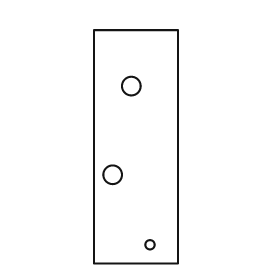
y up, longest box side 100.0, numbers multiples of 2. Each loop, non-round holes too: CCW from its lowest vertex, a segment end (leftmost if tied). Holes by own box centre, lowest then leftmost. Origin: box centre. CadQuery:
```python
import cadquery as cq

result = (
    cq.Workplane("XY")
    .moveTo(-18.0, -50.0)
    .lineTo(18.0, -50.0)
    .lineTo(18.0, 50.0)
    .lineTo(-18.0, 50.0)
    .close()
    .moveTo(6.0, -42.0)
    .circle(2.0)
    .moveTo(-10.0, -12.0)
    .circle(4.0)
    .moveTo(-2.0, 26.0)
    .circle(4.0)
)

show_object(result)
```